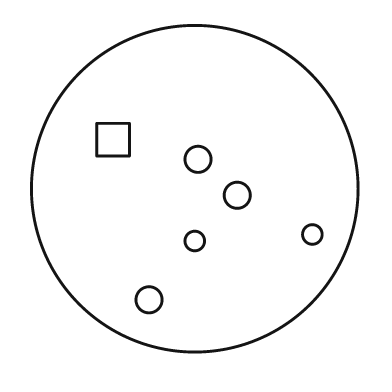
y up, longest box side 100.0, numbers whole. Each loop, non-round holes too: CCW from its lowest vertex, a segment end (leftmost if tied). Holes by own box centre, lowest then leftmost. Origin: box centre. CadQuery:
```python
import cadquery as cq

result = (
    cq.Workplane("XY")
    .moveTo(0.0, 0.0)
    .circle(50.0)
    .moveTo(-14.0, -34.0)
    .circle(4.0)
    .moveTo(0.0, -16.0)
    .circle(3.0)
    .moveTo(36.0, -14.0)
    .circle(3.0)
    .moveTo(13.0, -2.0)
    .circle(4.0)
    .moveTo(1.0, 9.0)
    .circle(4.0)
    .moveTo(-30.0, 10.0)
    .lineTo(-20.0, 10.0)
    .lineTo(-20.0, 20.0)
    .lineTo(-30.0, 20.0)
    .close()
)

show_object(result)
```